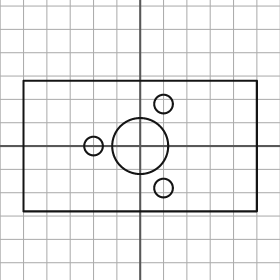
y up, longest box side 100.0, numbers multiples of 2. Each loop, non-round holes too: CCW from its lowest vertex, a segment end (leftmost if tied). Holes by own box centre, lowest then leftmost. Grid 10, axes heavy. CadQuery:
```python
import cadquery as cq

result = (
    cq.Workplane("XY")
    .moveTo(-50.0, -28.0)
    .lineTo(50.0, -28.0)
    .lineTo(50.0, 28.0)
    .lineTo(-50.0, 28.0)
    .close()
    .moveTo(10.0, -18.0)
    .circle(4.0)
    .moveTo(-20.0, 0.0)
    .circle(4.0)
    .moveTo(0.0, 0.0)
    .circle(12.0)
    .moveTo(10.0, 18.0)
    .circle(4.0)
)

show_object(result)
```